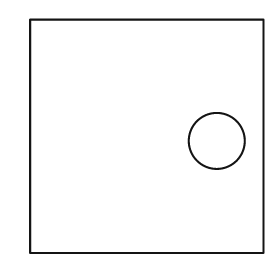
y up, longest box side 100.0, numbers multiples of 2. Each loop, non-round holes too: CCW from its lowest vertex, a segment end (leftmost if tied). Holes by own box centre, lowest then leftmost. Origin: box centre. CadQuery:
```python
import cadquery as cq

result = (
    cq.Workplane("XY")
    .moveTo(-50.0, -50.0)
    .lineTo(50.0, -50.0)
    .lineTo(50.0, 50.0)
    .lineTo(-50.0, 50.0)
    .close()
    .moveTo(30.0, -2.0)
    .circle(12.0)
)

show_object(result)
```